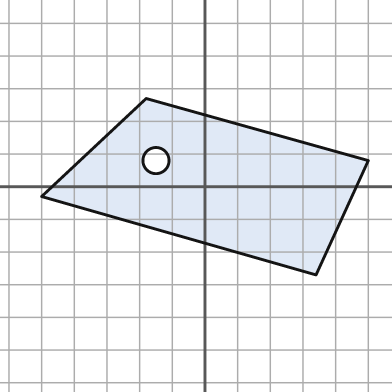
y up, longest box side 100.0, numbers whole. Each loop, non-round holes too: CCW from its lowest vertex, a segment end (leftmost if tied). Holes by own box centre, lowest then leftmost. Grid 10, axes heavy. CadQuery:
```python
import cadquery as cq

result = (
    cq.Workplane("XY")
    .moveTo(34.0, -27.0)
    .lineTo(50.0, 8.0)
    .lineTo(-18.0, 27.0)
    .lineTo(-50.0, -3.0)
    .close()
    .moveTo(-15.0, 8.0)
    .circle(4.0)
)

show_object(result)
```